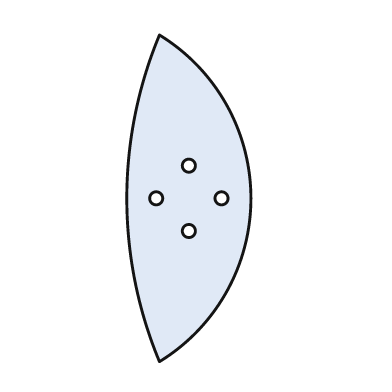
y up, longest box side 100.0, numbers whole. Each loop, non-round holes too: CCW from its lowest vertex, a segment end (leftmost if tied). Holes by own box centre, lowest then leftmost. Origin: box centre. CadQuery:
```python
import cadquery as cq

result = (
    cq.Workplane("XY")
    .moveTo(-9.0, -50.0)
    .threePointArc((19.0, 0.0), (-9.0, 50.0))
    .threePointArc((-19.0, 0.0), (-9.0, -50.0))
    .close()
    .moveTo(0.0, -10.0)
    .circle(2.0)
    .moveTo(-10.0, 0.0)
    .circle(2.0)
    .moveTo(10.0, 0.0)
    .circle(2.0)
    .moveTo(0.0, 10.0)
    .circle(2.0)
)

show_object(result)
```